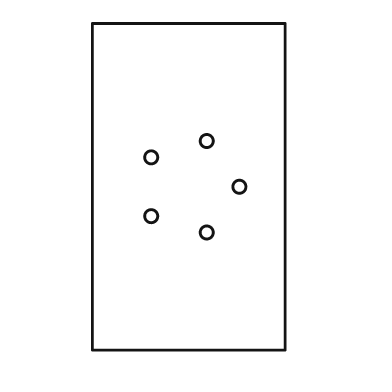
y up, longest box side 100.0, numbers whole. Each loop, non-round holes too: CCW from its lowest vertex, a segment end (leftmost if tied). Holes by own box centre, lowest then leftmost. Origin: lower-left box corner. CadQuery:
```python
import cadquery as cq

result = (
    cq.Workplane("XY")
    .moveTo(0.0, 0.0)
    .lineTo(59.0, 0.0)
    .lineTo(59.0, 100.0)
    .lineTo(0.0, 100.0)
    .close()
    .moveTo(35.0, 36.0)
    .circle(2.0)
    .moveTo(18.0, 41.0)
    .circle(2.0)
    .moveTo(45.0, 50.0)
    .circle(2.0)
    .moveTo(18.0, 59.0)
    .circle(2.0)
    .moveTo(35.0, 64.0)
    .circle(2.0)
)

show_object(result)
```